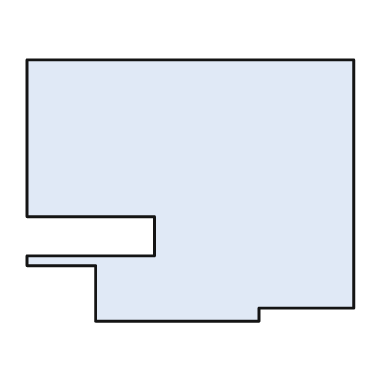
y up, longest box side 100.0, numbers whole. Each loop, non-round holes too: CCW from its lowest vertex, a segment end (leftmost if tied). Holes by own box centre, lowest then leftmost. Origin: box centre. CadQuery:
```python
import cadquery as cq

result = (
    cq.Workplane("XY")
    .moveTo(-29.0, -40.0)
    .lineTo(21.0, -40.0)
    .lineTo(21.0, -36.0)
    .lineTo(50.0, -36.0)
    .lineTo(50.0, 40.0)
    .lineTo(-50.0, 40.0)
    .lineTo(-50.0, -8.0)
    .lineTo(-11.0, -8.0)
    .lineTo(-11.0, -20.0)
    .lineTo(-50.0, -20.0)
    .lineTo(-50.0, -23.0)
    .lineTo(-29.0, -23.0)
    .close()
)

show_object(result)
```